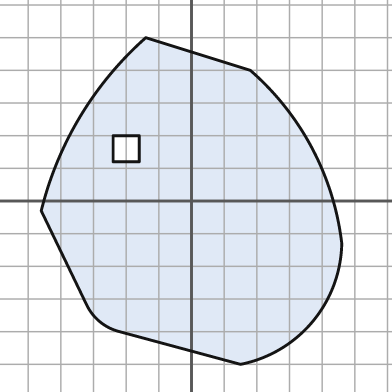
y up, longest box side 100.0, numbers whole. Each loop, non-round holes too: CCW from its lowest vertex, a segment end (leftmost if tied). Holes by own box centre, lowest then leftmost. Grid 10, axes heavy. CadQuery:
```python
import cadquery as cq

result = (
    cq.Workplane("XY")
    .moveTo(15.0, -50.0)
    .threePointArc((37.0, -37.0), (46.0, -13.0))
    .threePointArc((37.0, 16.0), (18.0, 40.0))
    .lineTo(-14.0, 50.0)
    .threePointArc((-34.0, 26.0), (-46.0, -3.0))
    .lineTo(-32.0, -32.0)
    .threePointArc((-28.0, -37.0), (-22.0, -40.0))
    .close()
    .moveTo(-24.0, 12.0)
    .lineTo(-16.0, 12.0)
    .lineTo(-16.0, 20.0)
    .lineTo(-24.0, 20.0)
    .close()
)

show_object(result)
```